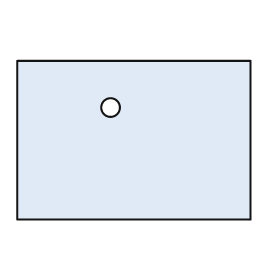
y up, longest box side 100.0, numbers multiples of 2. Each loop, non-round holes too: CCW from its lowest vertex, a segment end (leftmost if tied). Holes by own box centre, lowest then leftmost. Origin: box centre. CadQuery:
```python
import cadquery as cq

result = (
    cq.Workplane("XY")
    .moveTo(-50.0, -34.0)
    .lineTo(50.0, -34.0)
    .lineTo(50.0, 34.0)
    .lineTo(-50.0, 34.0)
    .close()
    .moveTo(-10.0, 14.0)
    .circle(4.0)
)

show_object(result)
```